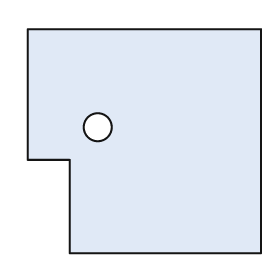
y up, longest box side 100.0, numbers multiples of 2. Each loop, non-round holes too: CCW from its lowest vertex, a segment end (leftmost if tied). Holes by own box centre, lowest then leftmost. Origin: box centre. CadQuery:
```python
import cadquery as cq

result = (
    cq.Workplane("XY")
    .moveTo(-32.0, -48.0)
    .lineTo(50.0, -48.0)
    .lineTo(50.0, 48.0)
    .lineTo(-50.0, 48.0)
    .lineTo(-50.0, -8.0)
    .lineTo(-32.0, -8.0)
    .close()
    .moveTo(-20.0, 6.0)
    .circle(6.0)
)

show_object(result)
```